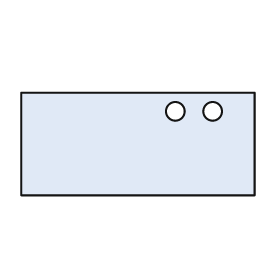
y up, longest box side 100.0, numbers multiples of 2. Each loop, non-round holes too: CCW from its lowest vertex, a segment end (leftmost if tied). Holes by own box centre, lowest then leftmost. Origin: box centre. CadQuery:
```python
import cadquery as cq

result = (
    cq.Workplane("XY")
    .moveTo(-50.0, -22.0)
    .lineTo(50.0, -22.0)
    .lineTo(50.0, 22.0)
    .lineTo(-50.0, 22.0)
    .close()
    .moveTo(16.0, 14.0)
    .circle(4.0)
    .moveTo(32.0, 14.0)
    .circle(4.0)
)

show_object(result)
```